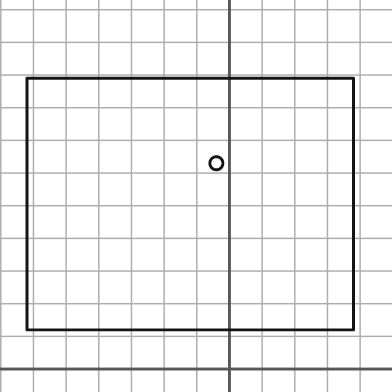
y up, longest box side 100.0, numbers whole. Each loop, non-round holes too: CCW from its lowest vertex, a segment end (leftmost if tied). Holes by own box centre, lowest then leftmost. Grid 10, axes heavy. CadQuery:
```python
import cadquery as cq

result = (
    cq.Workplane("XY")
    .moveTo(-62.0, 12.0)
    .lineTo(38.0, 12.0)
    .lineTo(38.0, 89.0)
    .lineTo(-62.0, 89.0)
    .close()
    .moveTo(-4.0, 63.0)
    .circle(2.0)
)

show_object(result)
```